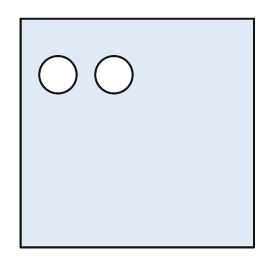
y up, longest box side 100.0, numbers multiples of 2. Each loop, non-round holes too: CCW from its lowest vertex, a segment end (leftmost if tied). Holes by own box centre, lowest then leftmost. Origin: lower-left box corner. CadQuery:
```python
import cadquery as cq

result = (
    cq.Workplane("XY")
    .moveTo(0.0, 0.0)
    .lineTo(100.0, 0.0)
    .lineTo(100.0, 98.0)
    .lineTo(0.0, 98.0)
    .close()
    .moveTo(16.0, 74.0)
    .circle(8.0)
    .moveTo(40.0, 74.0)
    .circle(8.0)
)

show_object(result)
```